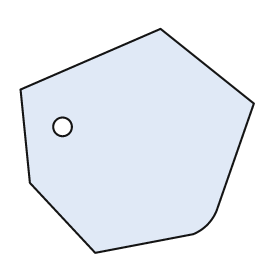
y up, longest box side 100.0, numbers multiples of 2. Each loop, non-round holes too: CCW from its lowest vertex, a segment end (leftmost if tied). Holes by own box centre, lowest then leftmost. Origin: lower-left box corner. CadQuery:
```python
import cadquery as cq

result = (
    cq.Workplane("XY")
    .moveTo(32.0, 0.0)
    .lineTo(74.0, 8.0)
    .threePointArc((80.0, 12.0), (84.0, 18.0))
    .lineTo(100.0, 64.0)
    .lineTo(60.0, 96.0)
    .lineTo(0.0, 70.0)
    .lineTo(4.0, 30.0)
    .close()
    .moveTo(18.0, 54.0)
    .circle(4.0)
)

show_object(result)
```